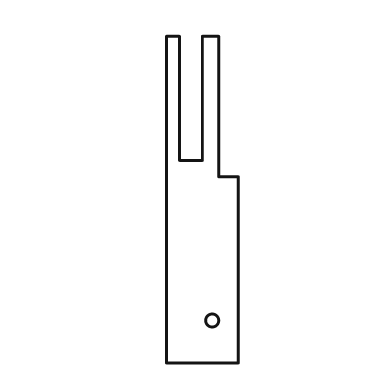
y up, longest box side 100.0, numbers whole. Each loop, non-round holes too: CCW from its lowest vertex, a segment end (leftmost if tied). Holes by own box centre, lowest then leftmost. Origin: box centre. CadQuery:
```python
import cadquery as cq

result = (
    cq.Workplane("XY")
    .moveTo(-11.0, -50.0)
    .lineTo(11.0, -50.0)
    .lineTo(11.0, 7.0)
    .lineTo(5.0, 7.0)
    .lineTo(5.0, 50.0)
    .lineTo(0.0, 50.0)
    .lineTo(0.0, 12.0)
    .lineTo(-7.0, 12.0)
    .lineTo(-7.0, 50.0)
    .lineTo(-11.0, 50.0)
    .close()
    .moveTo(3.0, -37.0)
    .circle(2.0)
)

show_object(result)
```